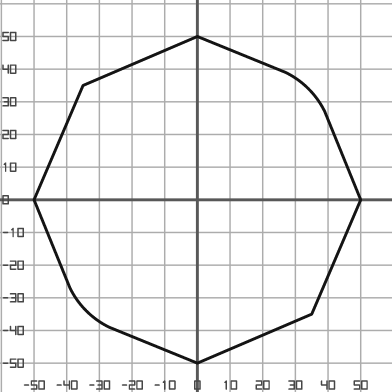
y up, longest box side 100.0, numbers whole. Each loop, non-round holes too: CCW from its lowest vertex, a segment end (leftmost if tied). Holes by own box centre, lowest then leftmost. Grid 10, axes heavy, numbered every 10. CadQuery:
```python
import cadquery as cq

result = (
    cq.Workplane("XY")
    .moveTo(0.0, -50.0)
    .lineTo(35.0, -35.0)
    .lineTo(50.0, 0.0)
    .lineTo(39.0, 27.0)
    .threePointArc((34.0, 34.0), (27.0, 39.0))
    .lineTo(0.0, 50.0)
    .lineTo(-35.0, 35.0)
    .lineTo(-50.0, 0.0)
    .lineTo(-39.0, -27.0)
    .threePointArc((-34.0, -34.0), (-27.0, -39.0))
    .close()
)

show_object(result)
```